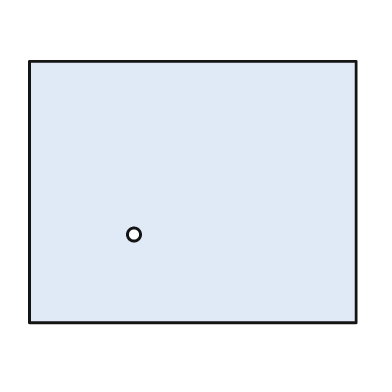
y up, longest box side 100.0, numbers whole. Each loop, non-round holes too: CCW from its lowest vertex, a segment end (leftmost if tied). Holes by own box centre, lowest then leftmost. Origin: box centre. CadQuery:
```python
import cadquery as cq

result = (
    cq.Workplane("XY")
    .moveTo(-50.0, -40.0)
    .lineTo(50.0, -40.0)
    .lineTo(50.0, 40.0)
    .lineTo(-50.0, 40.0)
    .close()
    .moveTo(-18.0, -13.0)
    .circle(2.0)
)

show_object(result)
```